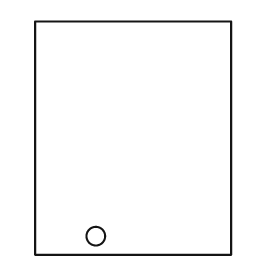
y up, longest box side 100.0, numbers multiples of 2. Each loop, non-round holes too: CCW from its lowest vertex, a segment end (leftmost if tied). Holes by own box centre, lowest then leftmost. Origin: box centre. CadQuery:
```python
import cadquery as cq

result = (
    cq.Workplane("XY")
    .moveTo(-42.0, -50.0)
    .lineTo(42.0, -50.0)
    .lineTo(42.0, 50.0)
    .lineTo(-42.0, 50.0)
    .close()
    .moveTo(-16.0, -42.0)
    .circle(4.0)
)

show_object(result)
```